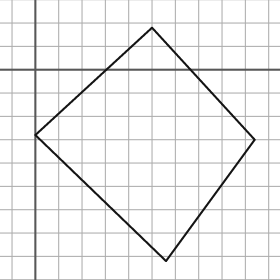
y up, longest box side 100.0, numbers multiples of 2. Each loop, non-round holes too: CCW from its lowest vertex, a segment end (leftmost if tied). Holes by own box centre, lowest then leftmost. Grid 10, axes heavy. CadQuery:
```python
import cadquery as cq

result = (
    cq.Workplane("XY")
    .moveTo(56.0, -82.0)
    .lineTo(94.0, -30.0)
    .lineTo(50.0, 18.0)
    .lineTo(0.0, -28.0)
    .close()
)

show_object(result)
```